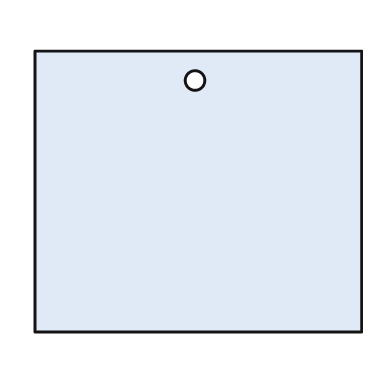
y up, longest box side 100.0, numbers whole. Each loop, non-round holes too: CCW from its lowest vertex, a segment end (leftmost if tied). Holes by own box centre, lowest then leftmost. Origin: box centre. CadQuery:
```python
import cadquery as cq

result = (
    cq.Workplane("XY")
    .moveTo(-50.0, -43.0)
    .lineTo(50.0, -43.0)
    .lineTo(50.0, 43.0)
    .lineTo(-50.0, 43.0)
    .close()
    .moveTo(-1.0, 34.0)
    .circle(3.0)
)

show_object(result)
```